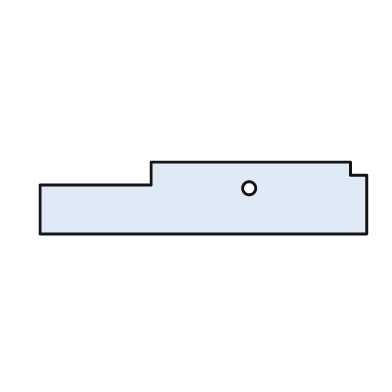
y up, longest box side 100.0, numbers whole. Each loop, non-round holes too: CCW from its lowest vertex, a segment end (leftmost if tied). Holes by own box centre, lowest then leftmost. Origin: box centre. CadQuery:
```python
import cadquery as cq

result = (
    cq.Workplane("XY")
    .moveTo(-50.0, -11.0)
    .lineTo(50.0, -11.0)
    .lineTo(50.0, 7.0)
    .lineTo(45.0, 7.0)
    .lineTo(45.0, 11.0)
    .lineTo(-16.0, 11.0)
    .lineTo(-16.0, 4.0)
    .lineTo(-50.0, 4.0)
    .close()
    .moveTo(14.0, 3.0)
    .circle(2.0)
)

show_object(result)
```